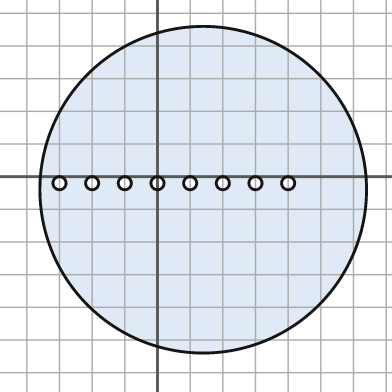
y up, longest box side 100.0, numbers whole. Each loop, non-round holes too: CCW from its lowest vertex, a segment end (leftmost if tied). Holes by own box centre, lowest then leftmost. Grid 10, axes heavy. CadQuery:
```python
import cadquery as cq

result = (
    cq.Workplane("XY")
    .moveTo(14.0, -4.0)
    .circle(50.0)
    .moveTo(-30.0, -2.0)
    .circle(2.0)
    .moveTo(-20.0, -2.0)
    .circle(2.0)
    .moveTo(-10.0, -2.0)
    .circle(2.0)
    .moveTo(0.0, -2.0)
    .circle(2.0)
    .moveTo(10.0, -2.0)
    .circle(2.0)
    .moveTo(20.0, -2.0)
    .circle(2.0)
    .moveTo(30.0, -2.0)
    .circle(2.0)
    .moveTo(40.0, -2.0)
    .circle(2.0)
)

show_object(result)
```